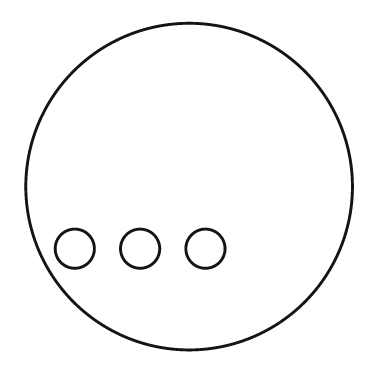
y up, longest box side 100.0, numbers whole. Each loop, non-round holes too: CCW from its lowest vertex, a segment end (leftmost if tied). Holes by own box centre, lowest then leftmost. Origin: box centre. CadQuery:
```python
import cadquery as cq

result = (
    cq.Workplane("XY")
    .moveTo(0.0, 0.0)
    .circle(50.0)
    .moveTo(-35.0, -19.0)
    .circle(6.0)
    .moveTo(-15.0, -19.0)
    .circle(6.0)
    .moveTo(5.0, -19.0)
    .circle(6.0)
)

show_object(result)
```